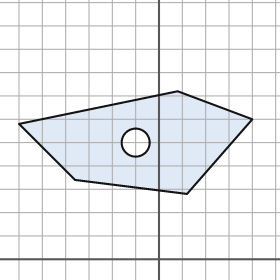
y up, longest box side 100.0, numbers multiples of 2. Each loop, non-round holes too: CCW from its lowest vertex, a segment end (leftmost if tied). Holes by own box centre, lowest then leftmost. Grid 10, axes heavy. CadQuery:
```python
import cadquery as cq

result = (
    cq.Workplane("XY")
    .moveTo(12.0, 28.0)
    .lineTo(40.0, 60.0)
    .lineTo(8.0, 72.0)
    .lineTo(-60.0, 58.0)
    .lineTo(-36.0, 34.0)
    .close()
    .moveTo(-10.0, 50.0)
    .circle(6.0)
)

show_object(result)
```